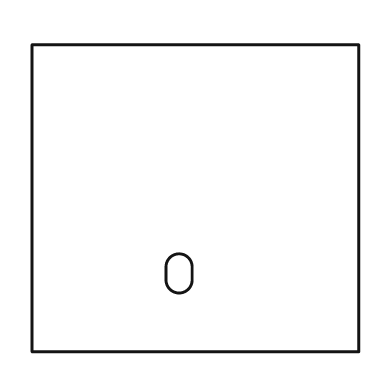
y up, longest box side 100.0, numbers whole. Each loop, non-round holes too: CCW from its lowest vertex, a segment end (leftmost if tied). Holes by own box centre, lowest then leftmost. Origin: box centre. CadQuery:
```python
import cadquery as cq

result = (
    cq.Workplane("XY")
    .moveTo(-50.0, -47.0)
    .lineTo(50.0, -47.0)
    .lineTo(50.0, 47.0)
    .lineTo(-50.0, 47.0)
    .close()
    .moveTo(-9.0, -25.0)
    .threePointArc((-5.0, -29.0), (-1.0, -25.0))
    .lineTo(-1.0, -21.0)
    .threePointArc((-5.0, -17.0), (-9.0, -21.0))
    .close()
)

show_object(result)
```